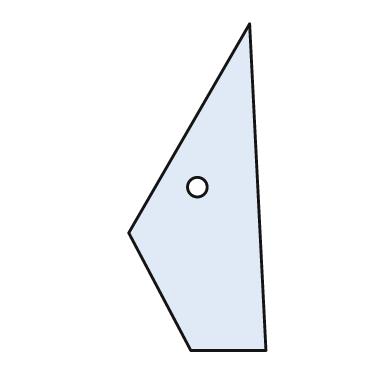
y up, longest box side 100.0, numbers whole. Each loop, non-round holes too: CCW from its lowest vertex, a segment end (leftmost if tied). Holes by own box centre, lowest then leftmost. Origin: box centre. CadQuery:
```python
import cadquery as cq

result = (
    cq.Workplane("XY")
    .moveTo(-2.0, -50.0)
    .lineTo(21.0, -50.0)
    .lineTo(16.0, 50.0)
    .lineTo(-21.0, -14.0)
    .close()
    .moveTo(0.0, 0.0)
    .circle(3.0)
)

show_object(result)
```